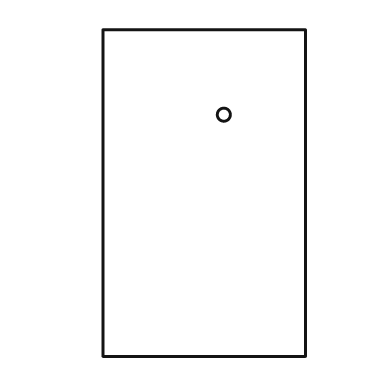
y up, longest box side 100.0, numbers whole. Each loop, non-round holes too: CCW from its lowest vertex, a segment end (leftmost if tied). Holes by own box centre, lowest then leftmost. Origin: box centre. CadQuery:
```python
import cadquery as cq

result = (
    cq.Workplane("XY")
    .moveTo(-31.0, -50.0)
    .lineTo(31.0, -50.0)
    .lineTo(31.0, 50.0)
    .lineTo(-31.0, 50.0)
    .close()
    .moveTo(6.0, 24.0)
    .circle(2.0)
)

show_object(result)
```